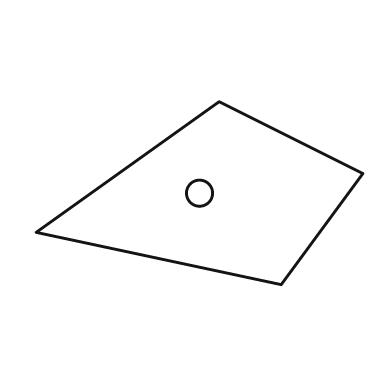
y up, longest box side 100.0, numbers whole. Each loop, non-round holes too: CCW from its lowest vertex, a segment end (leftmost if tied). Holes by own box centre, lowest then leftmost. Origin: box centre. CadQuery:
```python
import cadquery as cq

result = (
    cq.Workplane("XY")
    .moveTo(25.0, -28.0)
    .lineTo(50.0, 6.0)
    .lineTo(6.0, 28.0)
    .lineTo(-50.0, -12.0)
    .close()
    .moveTo(0.0, 0.0)
    .circle(4.0)
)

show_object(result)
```